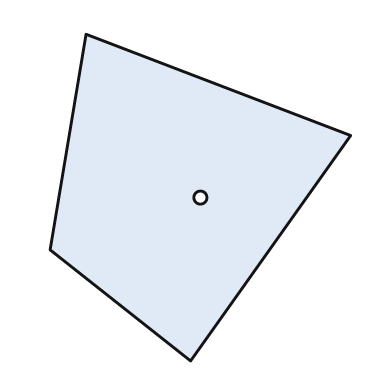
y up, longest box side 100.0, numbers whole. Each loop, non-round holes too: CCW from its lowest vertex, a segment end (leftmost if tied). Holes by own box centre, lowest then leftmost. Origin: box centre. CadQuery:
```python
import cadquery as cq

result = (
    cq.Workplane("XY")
    .moveTo(-3.0, -50.0)
    .lineTo(46.0, 19.0)
    .lineTo(-35.0, 50.0)
    .lineTo(-46.0, -16.0)
    .close()
    .moveTo(0.0, 0.0)
    .circle(2.0)
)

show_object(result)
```